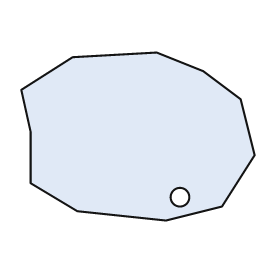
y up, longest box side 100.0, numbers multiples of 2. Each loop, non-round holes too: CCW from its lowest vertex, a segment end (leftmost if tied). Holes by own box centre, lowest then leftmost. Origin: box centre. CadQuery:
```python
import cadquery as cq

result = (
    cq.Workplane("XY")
    .moveTo(12.0, -36.0)
    .lineTo(36.0, -30.0)
    .lineTo(50.0, -8.0)
    .lineTo(44.0, 16.0)
    .lineTo(28.0, 28.0)
    .lineTo(8.0, 36.0)
    .lineTo(-28.0, 34.0)
    .lineTo(-50.0, 20.0)
    .lineTo(-46.0, 2.0)
    .lineTo(-46.0, -20.0)
    .lineTo(-26.0, -32.0)
    .close()
    .moveTo(18.0, -26.0)
    .circle(4.0)
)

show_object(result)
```